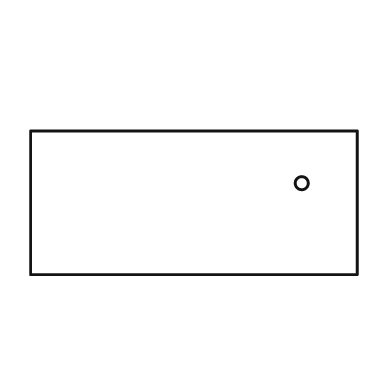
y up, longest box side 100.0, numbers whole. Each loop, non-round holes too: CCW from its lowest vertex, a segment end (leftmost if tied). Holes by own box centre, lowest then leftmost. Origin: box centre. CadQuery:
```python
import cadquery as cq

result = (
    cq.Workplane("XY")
    .moveTo(-50.0, -22.0)
    .lineTo(50.0, -22.0)
    .lineTo(50.0, 22.0)
    .lineTo(-50.0, 22.0)
    .close()
    .moveTo(33.0, 6.0)
    .circle(2.0)
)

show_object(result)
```